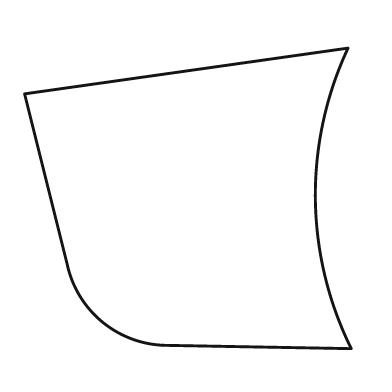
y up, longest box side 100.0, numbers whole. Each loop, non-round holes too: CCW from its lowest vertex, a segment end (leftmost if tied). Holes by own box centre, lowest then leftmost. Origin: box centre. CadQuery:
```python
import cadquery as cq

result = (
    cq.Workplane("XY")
    .moveTo(50.0, -46.0)
    .threePointArc((39.0, 0.0), (49.0, 46.0))
    .lineTo(-50.0, 32.0)
    .lineTo(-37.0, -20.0)
    .threePointArc((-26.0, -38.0), (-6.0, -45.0))
    .close()
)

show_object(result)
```